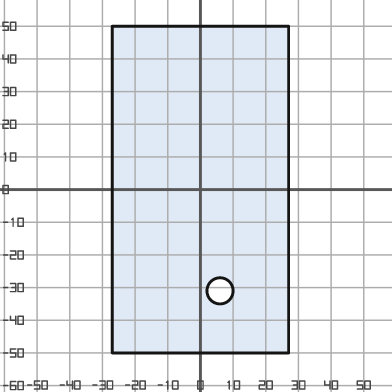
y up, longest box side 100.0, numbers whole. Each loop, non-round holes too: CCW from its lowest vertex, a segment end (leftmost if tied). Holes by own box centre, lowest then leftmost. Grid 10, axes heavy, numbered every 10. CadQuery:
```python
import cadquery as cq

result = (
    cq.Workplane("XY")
    .moveTo(-27.0, -50.0)
    .lineTo(27.0, -50.0)
    .lineTo(27.0, 50.0)
    .lineTo(-27.0, 50.0)
    .close()
    .moveTo(6.0, -31.0)
    .circle(4.0)
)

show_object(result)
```